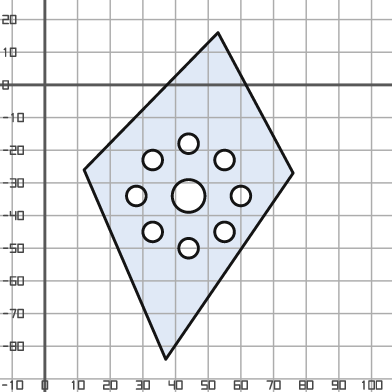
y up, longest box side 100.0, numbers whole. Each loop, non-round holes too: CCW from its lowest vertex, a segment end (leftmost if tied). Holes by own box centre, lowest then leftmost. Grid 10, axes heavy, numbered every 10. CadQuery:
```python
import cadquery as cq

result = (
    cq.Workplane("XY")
    .moveTo(37.0, -84.0)
    .lineTo(76.0, -27.0)
    .lineTo(53.0, 16.0)
    .lineTo(12.0, -26.0)
    .close()
    .moveTo(44.0, -50.0)
    .circle(3.0)
    .moveTo(33.0, -45.0)
    .circle(3.0)
    .moveTo(55.0, -45.0)
    .circle(3.0)
    .moveTo(28.0, -34.0)
    .circle(3.0)
    .moveTo(44.0, -34.0)
    .circle(5.0)
    .moveTo(60.0, -34.0)
    .circle(3.0)
    .moveTo(33.0, -23.0)
    .circle(3.0)
    .moveTo(55.0, -23.0)
    .circle(3.0)
    .moveTo(44.0, -18.0)
    .circle(3.0)
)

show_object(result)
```